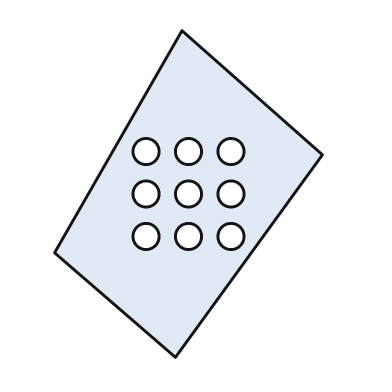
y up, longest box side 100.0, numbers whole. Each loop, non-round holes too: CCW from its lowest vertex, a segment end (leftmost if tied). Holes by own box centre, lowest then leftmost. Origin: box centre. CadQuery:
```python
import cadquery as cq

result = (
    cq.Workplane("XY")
    .moveTo(-4.0, -50.0)
    .lineTo(41.0, 12.0)
    .lineTo(-2.0, 50.0)
    .lineTo(-41.0, -18.0)
    .close()
    .moveTo(-13.0, -13.0)
    .circle(4.0)
    .moveTo(0.0, -13.0)
    .circle(4.0)
    .moveTo(13.0, -13.0)
    .circle(4.0)
    .moveTo(-13.0, 0.0)
    .circle(4.0)
    .moveTo(0.0, 0.0)
    .circle(4.0)
    .moveTo(13.0, 0.0)
    .circle(4.0)
    .moveTo(-13.0, 13.0)
    .circle(4.0)
    .moveTo(0.0, 13.0)
    .circle(4.0)
    .moveTo(13.0, 13.0)
    .circle(4.0)
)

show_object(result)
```